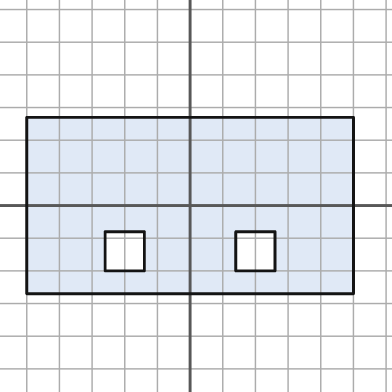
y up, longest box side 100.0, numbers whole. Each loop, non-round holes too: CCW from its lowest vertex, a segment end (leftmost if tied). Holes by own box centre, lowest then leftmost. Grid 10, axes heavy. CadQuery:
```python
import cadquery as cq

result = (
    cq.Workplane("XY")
    .moveTo(-50.0, -27.0)
    .lineTo(50.0, -27.0)
    .lineTo(50.0, 27.0)
    .lineTo(-50.0, 27.0)
    .close()
    .moveTo(-26.0, -20.0)
    .lineTo(-14.0, -20.0)
    .lineTo(-14.0, -8.0)
    .lineTo(-26.0, -8.0)
    .close()
    .moveTo(14.0, -20.0)
    .lineTo(26.0, -20.0)
    .lineTo(26.0, -8.0)
    .lineTo(14.0, -8.0)
    .close()
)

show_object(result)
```